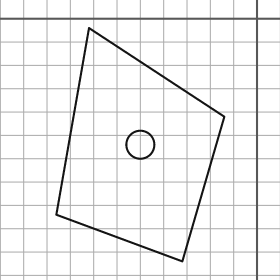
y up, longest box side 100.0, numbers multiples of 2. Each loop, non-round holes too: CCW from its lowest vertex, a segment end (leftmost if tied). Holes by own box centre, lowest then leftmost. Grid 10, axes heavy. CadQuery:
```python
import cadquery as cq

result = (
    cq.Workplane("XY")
    .moveTo(-32.0, -104.0)
    .lineTo(-14.0, -42.0)
    .lineTo(-72.0, -4.0)
    .lineTo(-86.0, -84.0)
    .close()
    .moveTo(-50.0, -54.0)
    .circle(6.0)
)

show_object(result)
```